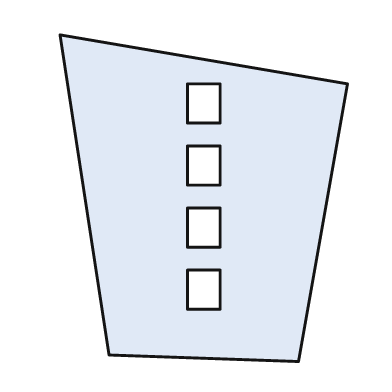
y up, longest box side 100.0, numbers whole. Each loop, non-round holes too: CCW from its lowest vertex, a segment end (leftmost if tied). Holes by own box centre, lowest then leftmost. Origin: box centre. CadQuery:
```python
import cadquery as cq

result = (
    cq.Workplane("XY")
    .moveTo(29.0, -50.0)
    .lineTo(44.0, 35.0)
    .lineTo(-44.0, 50.0)
    .lineTo(-29.0, -48.0)
    .close()
    .moveTo(-5.0, -34.0)
    .lineTo(5.0, -34.0)
    .lineTo(5.0, -22.0)
    .lineTo(-5.0, -22.0)
    .close()
    .moveTo(-5.0, -15.0)
    .lineTo(5.0, -15.0)
    .lineTo(5.0, -3.0)
    .lineTo(-5.0, -3.0)
    .close()
    .moveTo(-5.0, 4.0)
    .lineTo(5.0, 4.0)
    .lineTo(5.0, 16.0)
    .lineTo(-5.0, 16.0)
    .close()
    .moveTo(-5.0, 23.0)
    .lineTo(5.0, 23.0)
    .lineTo(5.0, 35.0)
    .lineTo(-5.0, 35.0)
    .close()
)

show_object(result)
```